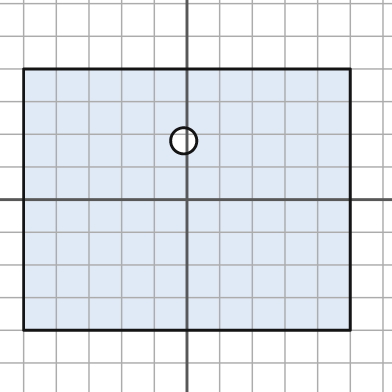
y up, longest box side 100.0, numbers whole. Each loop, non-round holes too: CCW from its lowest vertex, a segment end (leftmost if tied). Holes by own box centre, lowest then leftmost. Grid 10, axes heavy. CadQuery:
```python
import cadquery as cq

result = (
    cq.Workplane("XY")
    .moveTo(-50.0, -40.0)
    .lineTo(50.0, -40.0)
    .lineTo(50.0, 40.0)
    .lineTo(-50.0, 40.0)
    .close()
    .moveTo(-1.0, 18.0)
    .circle(4.0)
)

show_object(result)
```